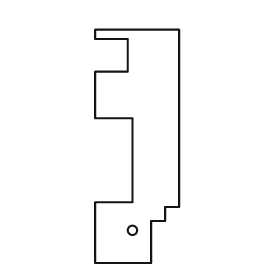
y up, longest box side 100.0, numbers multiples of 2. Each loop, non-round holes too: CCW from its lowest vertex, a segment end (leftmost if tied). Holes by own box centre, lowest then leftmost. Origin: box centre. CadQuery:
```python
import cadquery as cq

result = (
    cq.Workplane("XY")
    .moveTo(-18.0, -50.0)
    .lineTo(6.0, -50.0)
    .lineTo(6.0, -32.0)
    .lineTo(12.0, -32.0)
    .lineTo(12.0, -26.0)
    .lineTo(18.0, -26.0)
    .lineTo(18.0, 50.0)
    .lineTo(-18.0, 50.0)
    .lineTo(-18.0, 46.0)
    .lineTo(-4.0, 46.0)
    .lineTo(-4.0, 32.0)
    .lineTo(-18.0, 32.0)
    .lineTo(-18.0, 12.0)
    .lineTo(-2.0, 12.0)
    .lineTo(-2.0, -24.0)
    .lineTo(-18.0, -24.0)
    .close()
    .moveTo(-2.0, -36.0)
    .circle(2.0)
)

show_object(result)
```